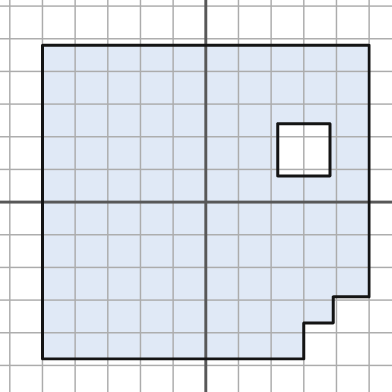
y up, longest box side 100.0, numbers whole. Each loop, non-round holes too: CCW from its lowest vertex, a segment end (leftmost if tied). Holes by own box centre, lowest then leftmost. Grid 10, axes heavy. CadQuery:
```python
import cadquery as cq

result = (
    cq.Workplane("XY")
    .moveTo(-50.0, -48.0)
    .lineTo(30.0, -48.0)
    .lineTo(30.0, -37.0)
    .lineTo(39.0, -37.0)
    .lineTo(39.0, -29.0)
    .lineTo(50.0, -29.0)
    .lineTo(50.0, 48.0)
    .lineTo(-50.0, 48.0)
    .close()
    .moveTo(22.0, 8.0)
    .lineTo(38.0, 8.0)
    .lineTo(38.0, 24.0)
    .lineTo(22.0, 24.0)
    .close()
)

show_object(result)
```